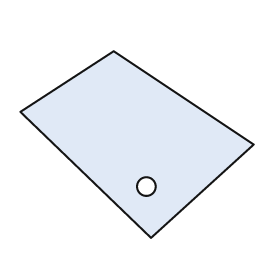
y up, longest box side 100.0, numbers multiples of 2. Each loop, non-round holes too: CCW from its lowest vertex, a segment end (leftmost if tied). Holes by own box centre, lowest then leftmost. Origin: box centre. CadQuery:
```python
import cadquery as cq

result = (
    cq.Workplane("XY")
    .moveTo(6.0, -40.0)
    .lineTo(50.0, 0.0)
    .lineTo(-10.0, 40.0)
    .lineTo(-50.0, 14.0)
    .close()
    .moveTo(4.0, -18.0)
    .circle(4.0)
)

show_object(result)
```